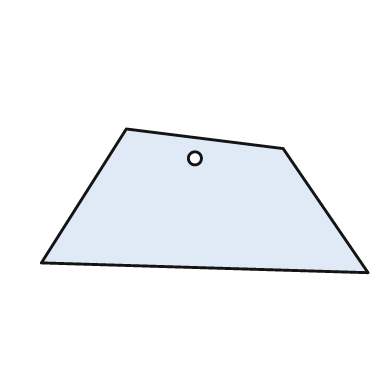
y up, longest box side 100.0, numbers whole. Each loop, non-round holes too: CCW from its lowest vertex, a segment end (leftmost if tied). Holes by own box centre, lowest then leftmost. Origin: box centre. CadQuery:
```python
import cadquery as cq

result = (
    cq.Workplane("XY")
    .moveTo(50.0, -22.0)
    .lineTo(24.0, 16.0)
    .lineTo(-24.0, 22.0)
    .lineTo(-50.0, -19.0)
    .close()
    .moveTo(-3.0, 13.0)
    .circle(2.0)
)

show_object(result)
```